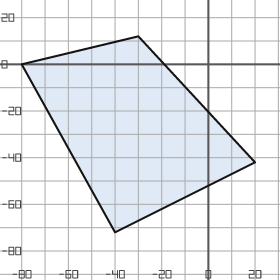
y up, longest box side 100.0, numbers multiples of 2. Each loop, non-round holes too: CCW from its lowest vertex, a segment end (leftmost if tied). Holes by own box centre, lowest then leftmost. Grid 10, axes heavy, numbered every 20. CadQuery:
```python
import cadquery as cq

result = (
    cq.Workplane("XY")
    .moveTo(-40.0, -72.0)
    .lineTo(20.0, -42.0)
    .lineTo(-30.0, 12.0)
    .lineTo(-80.0, 0.0)
    .close()
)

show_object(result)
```